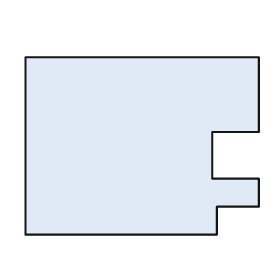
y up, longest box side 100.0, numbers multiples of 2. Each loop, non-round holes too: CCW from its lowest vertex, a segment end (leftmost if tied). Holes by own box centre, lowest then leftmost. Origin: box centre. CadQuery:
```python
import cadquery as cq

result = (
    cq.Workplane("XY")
    .moveTo(-50.0, -38.0)
    .lineTo(32.0, -38.0)
    .lineTo(32.0, -26.0)
    .lineTo(50.0, -26.0)
    .lineTo(50.0, -14.0)
    .lineTo(30.0, -14.0)
    .lineTo(30.0, 6.0)
    .lineTo(50.0, 6.0)
    .lineTo(50.0, 38.0)
    .lineTo(-50.0, 38.0)
    .close()
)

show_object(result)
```